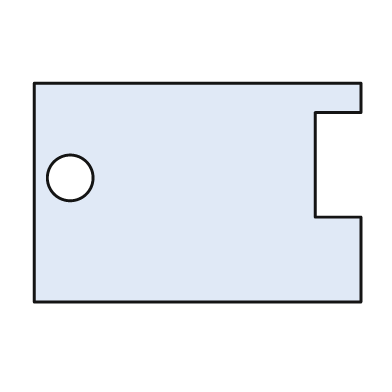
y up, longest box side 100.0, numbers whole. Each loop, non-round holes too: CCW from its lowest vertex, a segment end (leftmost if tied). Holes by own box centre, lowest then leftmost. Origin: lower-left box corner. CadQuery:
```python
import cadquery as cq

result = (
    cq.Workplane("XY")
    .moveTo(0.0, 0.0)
    .lineTo(100.0, 0.0)
    .lineTo(100.0, 26.0)
    .lineTo(86.0, 26.0)
    .lineTo(86.0, 58.0)
    .lineTo(100.0, 58.0)
    .lineTo(100.0, 67.0)
    .lineTo(0.0, 67.0)
    .close()
    .moveTo(11.0, 38.0)
    .circle(7.0)
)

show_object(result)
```